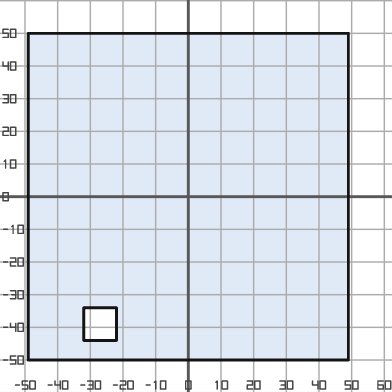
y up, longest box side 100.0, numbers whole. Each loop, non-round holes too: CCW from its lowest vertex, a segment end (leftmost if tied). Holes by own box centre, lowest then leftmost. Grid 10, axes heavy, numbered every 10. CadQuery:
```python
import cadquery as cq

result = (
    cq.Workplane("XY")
    .moveTo(-49.0, -50.0)
    .lineTo(49.0, -50.0)
    .lineTo(49.0, 50.0)
    .lineTo(-49.0, 50.0)
    .close()
    .moveTo(-32.0, -44.0)
    .lineTo(-22.0, -44.0)
    .lineTo(-22.0, -34.0)
    .lineTo(-32.0, -34.0)
    .close()
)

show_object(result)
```